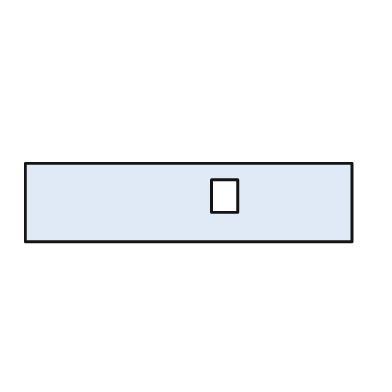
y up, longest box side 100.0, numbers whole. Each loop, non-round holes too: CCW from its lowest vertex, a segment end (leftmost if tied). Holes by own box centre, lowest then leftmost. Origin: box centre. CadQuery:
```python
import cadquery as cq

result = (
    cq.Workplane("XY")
    .moveTo(-50.0, -12.0)
    .lineTo(50.0, -12.0)
    .lineTo(50.0, 12.0)
    .lineTo(-50.0, 12.0)
    .close()
    .moveTo(7.0, -3.0)
    .lineTo(15.0, -3.0)
    .lineTo(15.0, 7.0)
    .lineTo(7.0, 7.0)
    .close()
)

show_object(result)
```